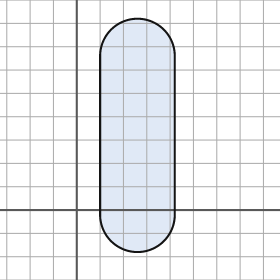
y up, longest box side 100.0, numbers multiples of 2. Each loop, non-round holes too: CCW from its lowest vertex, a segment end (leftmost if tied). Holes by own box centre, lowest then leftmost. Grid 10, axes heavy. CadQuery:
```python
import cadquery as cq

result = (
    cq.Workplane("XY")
    .moveTo(10.0, -2.0)
    .threePointArc((26.0, -18.0), (42.0, -2.0))
    .lineTo(42.0, 66.0)
    .threePointArc((26.0, 82.0), (10.0, 66.0))
    .close()
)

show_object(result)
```